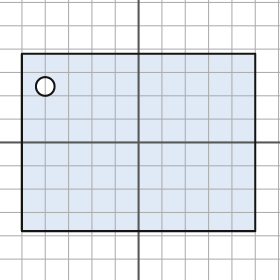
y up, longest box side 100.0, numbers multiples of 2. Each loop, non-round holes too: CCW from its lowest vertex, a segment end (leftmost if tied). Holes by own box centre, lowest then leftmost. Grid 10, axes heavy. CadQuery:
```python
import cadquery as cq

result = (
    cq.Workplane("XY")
    .moveTo(-50.0, -38.0)
    .lineTo(50.0, -38.0)
    .lineTo(50.0, 38.0)
    .lineTo(-50.0, 38.0)
    .close()
    .moveTo(-40.0, 24.0)
    .circle(4.0)
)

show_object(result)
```